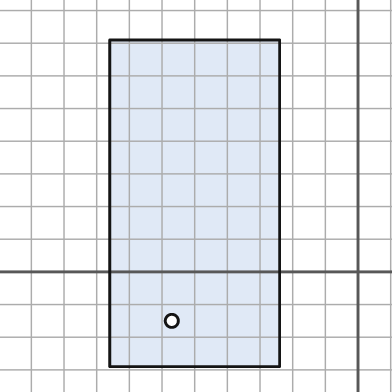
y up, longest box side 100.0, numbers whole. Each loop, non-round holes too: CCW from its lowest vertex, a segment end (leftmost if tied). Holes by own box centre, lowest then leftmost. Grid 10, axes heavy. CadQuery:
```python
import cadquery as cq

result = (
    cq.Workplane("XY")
    .moveTo(-76.0, -29.0)
    .lineTo(-24.0, -29.0)
    .lineTo(-24.0, 71.0)
    .lineTo(-76.0, 71.0)
    .close()
    .moveTo(-57.0, -15.0)
    .circle(2.0)
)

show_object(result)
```